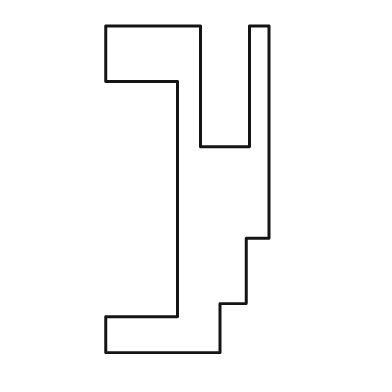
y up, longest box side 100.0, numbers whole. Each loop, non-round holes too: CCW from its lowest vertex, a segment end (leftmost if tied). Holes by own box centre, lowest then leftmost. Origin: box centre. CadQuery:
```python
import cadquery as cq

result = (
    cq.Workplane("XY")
    .moveTo(-25.0, -50.0)
    .lineTo(10.0, -50.0)
    .lineTo(10.0, -35.0)
    .lineTo(18.0, -35.0)
    .lineTo(18.0, -15.0)
    .lineTo(25.0, -15.0)
    .lineTo(25.0, 50.0)
    .lineTo(19.0, 50.0)
    .lineTo(19.0, 13.0)
    .lineTo(4.0, 13.0)
    .lineTo(4.0, 50.0)
    .lineTo(-25.0, 50.0)
    .lineTo(-25.0, 33.0)
    .lineTo(-3.0, 33.0)
    .lineTo(-3.0, -39.0)
    .lineTo(-25.0, -39.0)
    .close()
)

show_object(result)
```